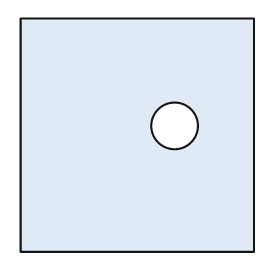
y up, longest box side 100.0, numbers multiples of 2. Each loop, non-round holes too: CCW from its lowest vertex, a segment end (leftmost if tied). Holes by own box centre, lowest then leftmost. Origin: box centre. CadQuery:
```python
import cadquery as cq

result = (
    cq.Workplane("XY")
    .moveTo(-50.0, -50.0)
    .lineTo(50.0, -50.0)
    .lineTo(50.0, 50.0)
    .lineTo(-50.0, 50.0)
    .close()
    .moveTo(16.0, 4.0)
    .circle(10.0)
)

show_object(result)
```